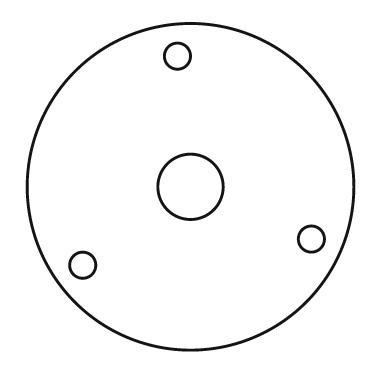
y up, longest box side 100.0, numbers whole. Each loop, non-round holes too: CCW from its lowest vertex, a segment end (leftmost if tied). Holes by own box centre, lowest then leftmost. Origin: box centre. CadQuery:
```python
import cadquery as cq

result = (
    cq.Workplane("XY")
    .moveTo(0.0, 0.0)
    .circle(50.0)
    .moveTo(-33.0, -24.0)
    .circle(4.0)
    .moveTo(37.0, -16.0)
    .circle(4.0)
    .moveTo(0.0, 0.0)
    .circle(10.0)
    .moveTo(-4.0, 40.0)
    .circle(4.0)
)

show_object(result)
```